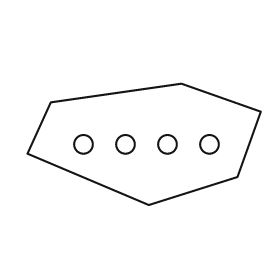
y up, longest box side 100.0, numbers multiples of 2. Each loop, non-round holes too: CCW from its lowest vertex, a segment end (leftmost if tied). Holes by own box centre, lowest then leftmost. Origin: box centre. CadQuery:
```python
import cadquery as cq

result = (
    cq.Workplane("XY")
    .moveTo(2.0, -26.0)
    .lineTo(40.0, -14.0)
    .lineTo(50.0, 14.0)
    .lineTo(16.0, 26.0)
    .lineTo(-40.0, 18.0)
    .lineTo(-50.0, -4.0)
    .close()
    .moveTo(-26.0, 0.0)
    .circle(4.0)
    .moveTo(-8.0, 0.0)
    .circle(4.0)
    .moveTo(10.0, 0.0)
    .circle(4.0)
    .moveTo(28.0, 0.0)
    .circle(4.0)
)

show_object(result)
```